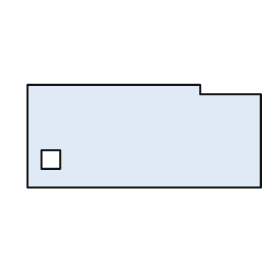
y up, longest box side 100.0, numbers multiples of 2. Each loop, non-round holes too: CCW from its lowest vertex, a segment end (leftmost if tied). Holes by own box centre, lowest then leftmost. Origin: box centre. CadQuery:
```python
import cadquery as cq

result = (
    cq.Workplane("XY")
    .moveTo(-50.0, -22.0)
    .lineTo(50.0, -22.0)
    .lineTo(50.0, 18.0)
    .lineTo(24.0, 18.0)
    .lineTo(24.0, 22.0)
    .lineTo(-50.0, 22.0)
    .close()
    .moveTo(-44.0, -14.0)
    .lineTo(-36.0, -14.0)
    .lineTo(-36.0, -6.0)
    .lineTo(-44.0, -6.0)
    .close()
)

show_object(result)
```